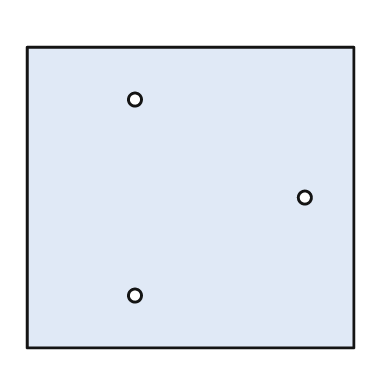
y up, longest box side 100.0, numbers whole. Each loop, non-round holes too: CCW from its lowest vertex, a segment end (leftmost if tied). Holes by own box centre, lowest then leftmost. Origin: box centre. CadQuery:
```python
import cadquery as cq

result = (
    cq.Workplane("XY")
    .moveTo(-50.0, -46.0)
    .lineTo(50.0, -46.0)
    .lineTo(50.0, 46.0)
    .lineTo(-50.0, 46.0)
    .close()
    .moveTo(-17.0, -30.0)
    .circle(2.0)
    .moveTo(35.0, 0.0)
    .circle(2.0)
    .moveTo(-17.0, 30.0)
    .circle(2.0)
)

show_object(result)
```